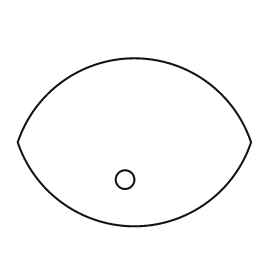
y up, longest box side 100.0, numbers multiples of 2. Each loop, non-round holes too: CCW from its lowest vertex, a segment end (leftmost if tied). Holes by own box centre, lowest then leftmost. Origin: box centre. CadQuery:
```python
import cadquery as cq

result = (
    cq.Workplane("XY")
    .moveTo(-50.0, 0.0)
    .threePointArc((0.0, -36.0), (50.0, 0.0))
    .threePointArc((0.0, 36.0), (-50.0, 0.0))
    .close()
    .moveTo(-4.0, -16.0)
    .circle(4.0)
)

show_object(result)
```